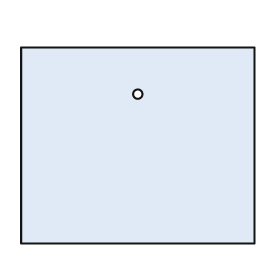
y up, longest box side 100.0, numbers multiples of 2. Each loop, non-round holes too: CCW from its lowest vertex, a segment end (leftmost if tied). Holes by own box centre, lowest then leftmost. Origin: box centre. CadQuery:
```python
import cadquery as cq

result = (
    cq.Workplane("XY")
    .moveTo(-50.0, -42.0)
    .lineTo(50.0, -42.0)
    .lineTo(50.0, 42.0)
    .lineTo(-50.0, 42.0)
    .close()
    .moveTo(0.0, 22.0)
    .circle(2.0)
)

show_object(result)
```